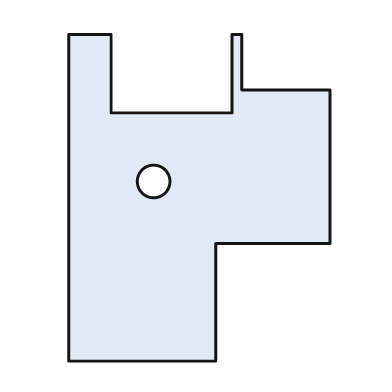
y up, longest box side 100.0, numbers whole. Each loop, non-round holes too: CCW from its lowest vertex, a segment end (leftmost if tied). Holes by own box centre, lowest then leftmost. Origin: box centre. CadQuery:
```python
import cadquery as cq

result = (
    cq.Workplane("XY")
    .moveTo(-40.0, -50.0)
    .lineTo(5.0, -50.0)
    .lineTo(5.0, -14.0)
    .lineTo(40.0, -14.0)
    .lineTo(40.0, 33.0)
    .lineTo(13.0, 33.0)
    .lineTo(13.0, 50.0)
    .lineTo(10.0, 50.0)
    .lineTo(10.0, 26.0)
    .lineTo(-27.0, 26.0)
    .lineTo(-27.0, 50.0)
    .lineTo(-40.0, 50.0)
    .close()
    .moveTo(-14.0, 5.0)
    .circle(5.0)
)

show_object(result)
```